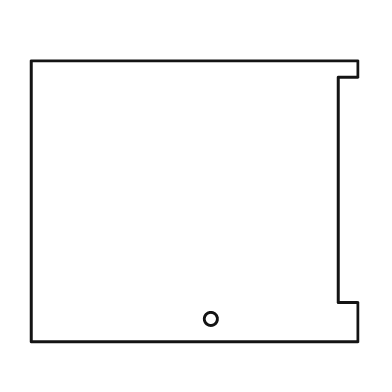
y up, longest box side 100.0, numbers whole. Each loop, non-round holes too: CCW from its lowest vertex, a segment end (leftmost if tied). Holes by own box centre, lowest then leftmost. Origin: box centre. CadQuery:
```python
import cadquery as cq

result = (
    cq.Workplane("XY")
    .moveTo(-50.0, -43.0)
    .lineTo(50.0, -43.0)
    .lineTo(50.0, -31.0)
    .lineTo(44.0, -31.0)
    .lineTo(44.0, 38.0)
    .lineTo(50.0, 38.0)
    .lineTo(50.0, 43.0)
    .lineTo(-50.0, 43.0)
    .close()
    .moveTo(5.0, -36.0)
    .circle(2.0)
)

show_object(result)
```